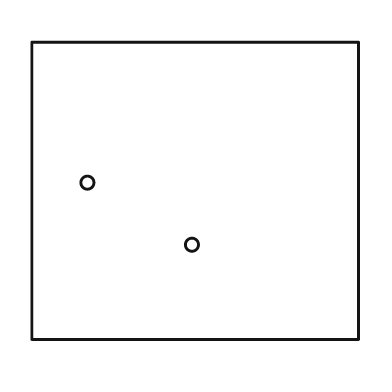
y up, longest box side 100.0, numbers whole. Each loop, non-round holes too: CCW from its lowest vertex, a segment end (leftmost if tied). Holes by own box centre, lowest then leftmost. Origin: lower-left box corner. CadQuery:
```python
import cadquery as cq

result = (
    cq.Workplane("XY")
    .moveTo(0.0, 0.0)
    .lineTo(100.0, 0.0)
    .lineTo(100.0, 91.0)
    .lineTo(0.0, 91.0)
    .close()
    .moveTo(49.0, 29.0)
    .circle(2.0)
    .moveTo(17.0, 48.0)
    .circle(2.0)
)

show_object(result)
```